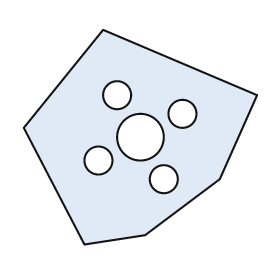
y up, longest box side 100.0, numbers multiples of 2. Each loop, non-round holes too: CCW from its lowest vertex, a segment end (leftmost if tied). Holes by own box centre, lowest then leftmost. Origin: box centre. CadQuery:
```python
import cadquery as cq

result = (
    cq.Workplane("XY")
    .moveTo(-24.0, -46.0)
    .lineTo(2.0, -42.0)
    .lineTo(34.0, -18.0)
    .lineTo(50.0, 18.0)
    .lineTo(-16.0, 46.0)
    .lineTo(-50.0, 4.0)
    .close()
    .moveTo(10.0, -18.0)
    .circle(6.0)
    .moveTo(-18.0, -10.0)
    .circle(6.0)
    .moveTo(0.0, 0.0)
    .circle(10.0)
    .moveTo(18.0, 10.0)
    .circle(6.0)
    .moveTo(-10.0, 18.0)
    .circle(6.0)
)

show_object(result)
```